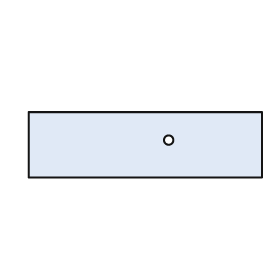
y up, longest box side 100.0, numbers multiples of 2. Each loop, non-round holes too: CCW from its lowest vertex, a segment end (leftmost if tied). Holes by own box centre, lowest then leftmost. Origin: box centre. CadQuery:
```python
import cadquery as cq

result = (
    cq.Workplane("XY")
    .moveTo(-50.0, -14.0)
    .lineTo(50.0, -14.0)
    .lineTo(50.0, 14.0)
    .lineTo(-50.0, 14.0)
    .close()
    .moveTo(10.0, 2.0)
    .circle(2.0)
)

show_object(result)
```